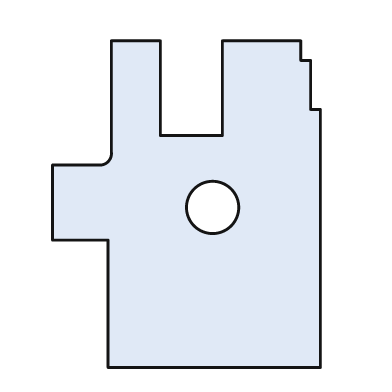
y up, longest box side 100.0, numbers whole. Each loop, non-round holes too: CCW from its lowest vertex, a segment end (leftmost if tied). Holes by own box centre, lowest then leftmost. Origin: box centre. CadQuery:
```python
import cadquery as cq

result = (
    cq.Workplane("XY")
    .moveTo(-24.0, -50.0)
    .lineTo(41.0, -50.0)
    .lineTo(41.0, 29.0)
    .lineTo(38.0, 29.0)
    .lineTo(38.0, 44.0)
    .lineTo(35.0, 44.0)
    .lineTo(35.0, 50.0)
    .lineTo(11.0, 50.0)
    .lineTo(11.0, 21.0)
    .lineTo(-8.0, 21.0)
    .lineTo(-8.0, 50.0)
    .lineTo(-23.0, 50.0)
    .lineTo(-23.0, 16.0)
    .threePointArc((-24.0, 13.0), (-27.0, 12.0))
    .lineTo(-41.0, 12.0)
    .lineTo(-41.0, -11.0)
    .lineTo(-24.0, -11.0)
    .close()
    .moveTo(8.0, -1.0)
    .circle(8.0)
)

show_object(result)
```